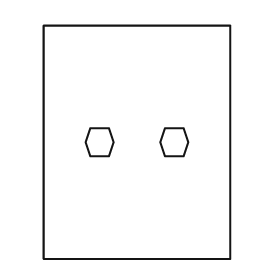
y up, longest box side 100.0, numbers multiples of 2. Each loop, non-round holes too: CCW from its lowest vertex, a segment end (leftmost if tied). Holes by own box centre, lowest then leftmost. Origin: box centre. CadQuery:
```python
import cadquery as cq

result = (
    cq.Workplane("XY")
    .moveTo(-40.0, -50.0)
    .lineTo(40.0, -50.0)
    .lineTo(40.0, 50.0)
    .lineTo(-40.0, 50.0)
    .close()
    .moveTo(-20.0, -6.0)
    .lineTo(-12.0, -6.0)
    .lineTo(-10.0, 0.0)
    .lineTo(-12.0, 6.0)
    .lineTo(-20.0, 6.0)
    .lineTo(-22.0, 0.0)
    .close()
    .moveTo(12.0, -6.0)
    .lineTo(20.0, -6.0)
    .lineTo(22.0, 0.0)
    .lineTo(20.0, 6.0)
    .lineTo(12.0, 6.0)
    .lineTo(10.0, 0.0)
    .close()
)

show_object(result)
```